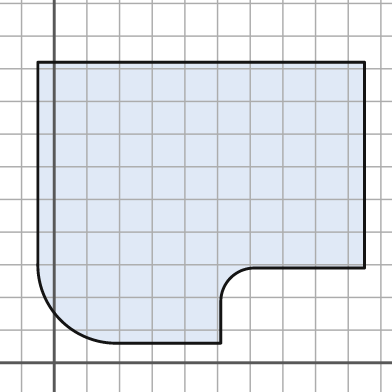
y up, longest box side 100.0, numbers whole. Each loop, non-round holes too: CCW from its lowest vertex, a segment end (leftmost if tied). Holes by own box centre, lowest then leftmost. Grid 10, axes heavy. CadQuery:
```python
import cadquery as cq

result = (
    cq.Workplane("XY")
    .moveTo(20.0, 6.0)
    .lineTo(51.0, 6.0)
    .lineTo(51.0, 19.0)
    .threePointArc((54.0, 26.0), (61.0, 29.0))
    .lineTo(95.0, 29.0)
    .lineTo(95.0, 92.0)
    .lineTo(-5.0, 92.0)
    .lineTo(-5.0, 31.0)
    .threePointArc((2.0, 13.0), (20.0, 6.0))
    .close()
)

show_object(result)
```